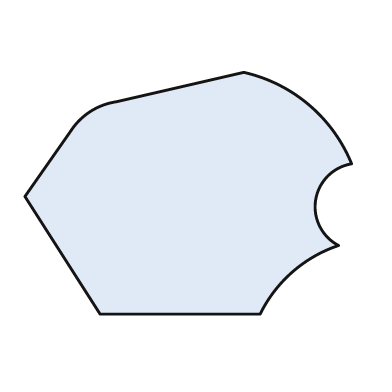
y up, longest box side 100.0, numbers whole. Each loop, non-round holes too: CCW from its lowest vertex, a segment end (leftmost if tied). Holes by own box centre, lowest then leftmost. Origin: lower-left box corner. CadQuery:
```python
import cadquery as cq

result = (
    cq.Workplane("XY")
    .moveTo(23.0, 0.0)
    .lineTo(72.0, 0.0)
    .threePointArc((82.0, 13.0), (96.0, 21.0))
    .threePointArc((89.0, 35.0), (100.0, 46.0))
    .threePointArc((87.0, 64.0), (67.0, 74.0))
    .lineTo(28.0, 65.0)
    .threePointArc((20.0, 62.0), (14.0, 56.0))
    .lineTo(0.0, 36.0)
    .close()
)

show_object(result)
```